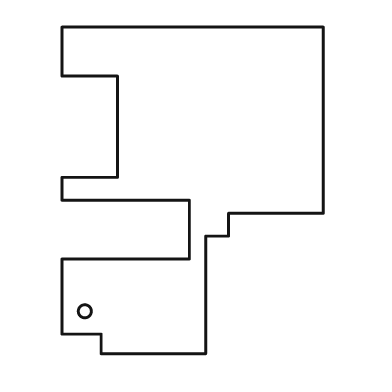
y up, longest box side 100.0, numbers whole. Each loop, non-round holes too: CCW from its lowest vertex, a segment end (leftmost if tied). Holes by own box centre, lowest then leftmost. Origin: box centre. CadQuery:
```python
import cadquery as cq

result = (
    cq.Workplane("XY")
    .moveTo(-28.0, -50.0)
    .lineTo(4.0, -50.0)
    .lineTo(4.0, -14.0)
    .lineTo(11.0, -14.0)
    .lineTo(11.0, -7.0)
    .lineTo(40.0, -7.0)
    .lineTo(40.0, 50.0)
    .lineTo(-40.0, 50.0)
    .lineTo(-40.0, 35.0)
    .lineTo(-23.0, 35.0)
    .lineTo(-23.0, 4.0)
    .lineTo(-40.0, 4.0)
    .lineTo(-40.0, -3.0)
    .lineTo(-1.0, -3.0)
    .lineTo(-1.0, -21.0)
    .lineTo(-40.0, -21.0)
    .lineTo(-40.0, -44.0)
    .lineTo(-28.0, -44.0)
    .close()
    .moveTo(-33.0, -37.0)
    .circle(2.0)
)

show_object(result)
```